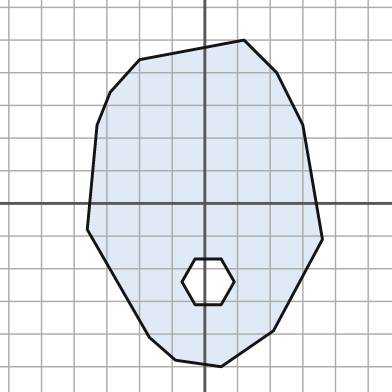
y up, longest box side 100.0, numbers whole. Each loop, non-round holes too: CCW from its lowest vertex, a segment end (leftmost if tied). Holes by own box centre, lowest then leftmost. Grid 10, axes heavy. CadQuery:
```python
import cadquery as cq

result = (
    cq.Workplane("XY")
    .moveTo(5.0, -50.0)
    .lineTo(21.0, -39.0)
    .lineTo(36.0, -11.0)
    .lineTo(30.0, 24.0)
    .lineTo(22.0, 40.0)
    .lineTo(12.0, 50.0)
    .lineTo(-20.0, 44.0)
    .lineTo(-29.0, 34.0)
    .lineTo(-33.0, 24.0)
    .lineTo(-36.0, -8.0)
    .lineTo(-17.0, -41.0)
    .lineTo(-9.0, -48.0)
    .close()
    .moveTo(-3.0, -31.0)
    .lineTo(5.0, -31.0)
    .lineTo(9.0, -24.0)
    .lineTo(5.0, -17.0)
    .lineTo(-3.0, -17.0)
    .lineTo(-7.0, -24.0)
    .close()
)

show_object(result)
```